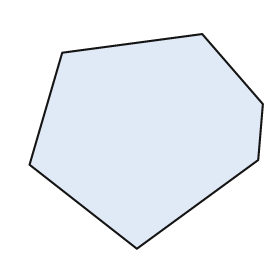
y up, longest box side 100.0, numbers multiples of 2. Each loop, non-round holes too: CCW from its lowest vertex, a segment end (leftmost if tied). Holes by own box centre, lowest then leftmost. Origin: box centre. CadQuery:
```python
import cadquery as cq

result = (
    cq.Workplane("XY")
    .moveTo(-4.0, -46.0)
    .lineTo(48.0, -8.0)
    .lineTo(50.0, 16.0)
    .lineTo(24.0, 46.0)
    .lineTo(-36.0, 38.0)
    .lineTo(-50.0, -10.0)
    .close()
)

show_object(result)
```